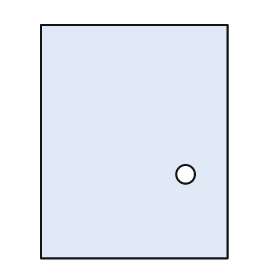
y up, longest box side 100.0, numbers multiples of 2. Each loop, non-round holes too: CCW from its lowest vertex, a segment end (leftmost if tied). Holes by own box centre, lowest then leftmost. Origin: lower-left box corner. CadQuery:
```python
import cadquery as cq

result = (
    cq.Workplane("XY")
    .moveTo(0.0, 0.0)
    .lineTo(80.0, 0.0)
    .lineTo(80.0, 100.0)
    .lineTo(0.0, 100.0)
    .close()
    .moveTo(62.0, 36.0)
    .circle(4.0)
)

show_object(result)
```